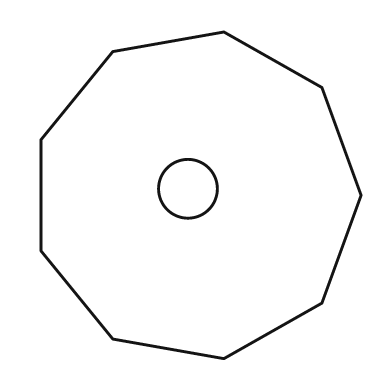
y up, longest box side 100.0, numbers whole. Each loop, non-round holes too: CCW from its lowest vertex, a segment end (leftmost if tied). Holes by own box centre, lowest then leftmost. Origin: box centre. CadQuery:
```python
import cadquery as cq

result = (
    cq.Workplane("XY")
    .moveTo(7.0, -50.0)
    .lineTo(37.0, -33.0)
    .lineTo(49.0, 0.0)
    .lineTo(37.0, 33.0)
    .lineTo(7.0, 50.0)
    .lineTo(-27.0, 44.0)
    .lineTo(-49.0, 17.0)
    .lineTo(-49.0, -17.0)
    .lineTo(-27.0, -44.0)
    .close()
    .moveTo(-4.0, 2.0)
    .circle(9.0)
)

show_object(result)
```